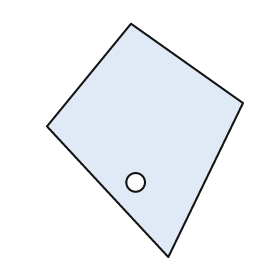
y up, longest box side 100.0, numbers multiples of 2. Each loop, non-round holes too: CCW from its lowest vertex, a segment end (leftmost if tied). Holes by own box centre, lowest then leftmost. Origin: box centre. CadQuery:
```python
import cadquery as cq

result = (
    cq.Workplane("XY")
    .moveTo(10.0, -50.0)
    .lineTo(42.0, 16.0)
    .lineTo(-6.0, 50.0)
    .lineTo(-42.0, 6.0)
    .close()
    .moveTo(-4.0, -18.0)
    .circle(4.0)
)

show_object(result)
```